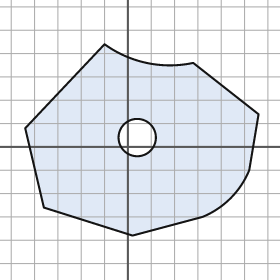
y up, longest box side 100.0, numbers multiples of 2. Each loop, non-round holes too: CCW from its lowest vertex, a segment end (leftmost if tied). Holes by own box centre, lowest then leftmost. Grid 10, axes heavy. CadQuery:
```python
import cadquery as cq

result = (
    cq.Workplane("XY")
    .moveTo(2.0, -38.0)
    .lineTo(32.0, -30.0)
    .threePointArc((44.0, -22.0), (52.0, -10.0))
    .lineTo(56.0, 14.0)
    .lineTo(28.0, 36.0)
    .threePointArc((8.0, 36.0), (-10.0, 44.0))
    .lineTo(-44.0, 8.0)
    .lineTo(-36.0, -26.0)
    .close()
    .moveTo(4.0, 4.0)
    .circle(8.0)
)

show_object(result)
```